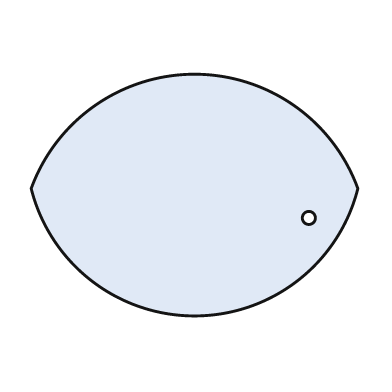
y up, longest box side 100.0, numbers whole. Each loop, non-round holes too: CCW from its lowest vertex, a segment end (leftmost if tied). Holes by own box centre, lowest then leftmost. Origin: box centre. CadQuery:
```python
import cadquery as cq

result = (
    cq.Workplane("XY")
    .moveTo(-50.0, 2.0)
    .threePointArc((0.0, -37.0), (50.0, 2.0))
    .threePointArc((0.0, 37.0), (-50.0, 2.0))
    .close()
    .moveTo(35.0, -7.0)
    .circle(2.0)
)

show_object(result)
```